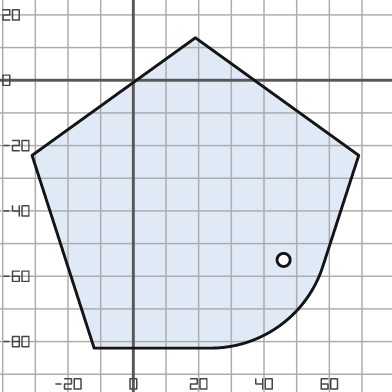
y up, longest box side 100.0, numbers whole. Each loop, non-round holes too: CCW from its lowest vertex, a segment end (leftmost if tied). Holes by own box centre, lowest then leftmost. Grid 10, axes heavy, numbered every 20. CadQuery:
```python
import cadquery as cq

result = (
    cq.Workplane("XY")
    .moveTo(-12.0, -82.0)
    .lineTo(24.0, -82.0)
    .threePointArc((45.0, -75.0), (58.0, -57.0))
    .lineTo(69.0, -23.0)
    .lineTo(19.0, 13.0)
    .lineTo(-31.0, -23.0)
    .close()
    .moveTo(46.0, -55.0)
    .circle(2.0)
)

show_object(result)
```